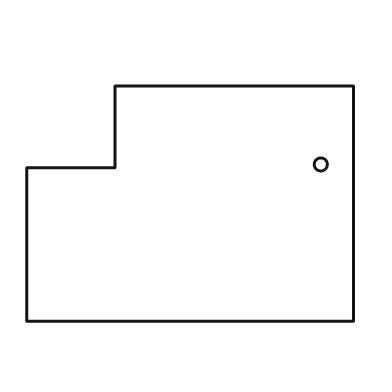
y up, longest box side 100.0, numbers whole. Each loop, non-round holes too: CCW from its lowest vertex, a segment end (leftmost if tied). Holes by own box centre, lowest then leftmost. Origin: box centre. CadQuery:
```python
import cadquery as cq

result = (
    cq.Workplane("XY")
    .moveTo(-50.0, -36.0)
    .lineTo(50.0, -36.0)
    .lineTo(50.0, 36.0)
    .lineTo(-23.0, 36.0)
    .lineTo(-23.0, 11.0)
    .lineTo(-50.0, 11.0)
    .close()
    .moveTo(40.0, 12.0)
    .circle(2.0)
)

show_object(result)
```